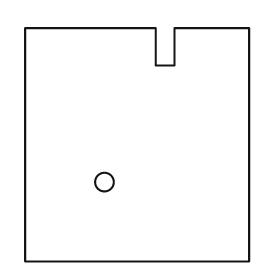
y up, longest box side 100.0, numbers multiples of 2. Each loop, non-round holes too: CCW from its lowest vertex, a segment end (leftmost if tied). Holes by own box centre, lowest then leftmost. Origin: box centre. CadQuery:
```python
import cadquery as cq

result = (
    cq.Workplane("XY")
    .moveTo(-48.0, -50.0)
    .lineTo(48.0, -50.0)
    .lineTo(48.0, 50.0)
    .lineTo(16.0, 50.0)
    .lineTo(16.0, 34.0)
    .lineTo(8.0, 34.0)
    .lineTo(8.0, 50.0)
    .lineTo(-48.0, 50.0)
    .close()
    .moveTo(-14.0, -16.0)
    .circle(4.0)
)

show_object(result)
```